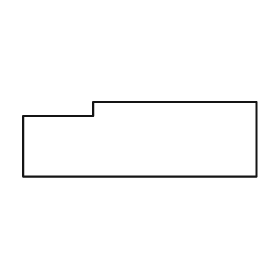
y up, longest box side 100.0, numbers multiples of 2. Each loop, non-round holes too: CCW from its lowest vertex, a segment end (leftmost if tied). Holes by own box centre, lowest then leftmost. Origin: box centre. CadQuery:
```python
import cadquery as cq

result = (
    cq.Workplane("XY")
    .moveTo(-50.0, -16.0)
    .lineTo(50.0, -16.0)
    .lineTo(50.0, 16.0)
    .lineTo(-20.0, 16.0)
    .lineTo(-20.0, 10.0)
    .lineTo(-50.0, 10.0)
    .close()
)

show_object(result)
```